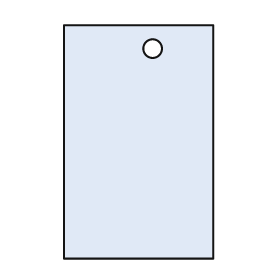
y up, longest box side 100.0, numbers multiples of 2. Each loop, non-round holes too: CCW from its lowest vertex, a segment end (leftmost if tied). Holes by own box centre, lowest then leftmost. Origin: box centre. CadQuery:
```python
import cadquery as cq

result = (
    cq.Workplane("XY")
    .moveTo(-32.0, -50.0)
    .lineTo(32.0, -50.0)
    .lineTo(32.0, 50.0)
    .lineTo(-32.0, 50.0)
    .close()
    .moveTo(6.0, 40.0)
    .circle(4.0)
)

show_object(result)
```